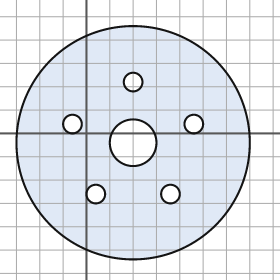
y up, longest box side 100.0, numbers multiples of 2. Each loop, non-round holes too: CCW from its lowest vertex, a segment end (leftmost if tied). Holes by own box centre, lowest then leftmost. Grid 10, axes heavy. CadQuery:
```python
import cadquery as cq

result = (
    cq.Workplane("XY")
    .moveTo(20.0, -4.0)
    .circle(50.0)
    .moveTo(4.0, -26.0)
    .circle(4.0)
    .moveTo(36.0, -26.0)
    .circle(4.0)
    .moveTo(20.0, -4.0)
    .circle(10.0)
    .moveTo(-6.0, 4.0)
    .circle(4.0)
    .moveTo(46.0, 4.0)
    .circle(4.0)
    .moveTo(20.0, 22.0)
    .circle(4.0)
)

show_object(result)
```